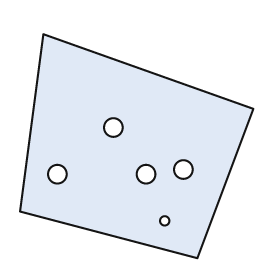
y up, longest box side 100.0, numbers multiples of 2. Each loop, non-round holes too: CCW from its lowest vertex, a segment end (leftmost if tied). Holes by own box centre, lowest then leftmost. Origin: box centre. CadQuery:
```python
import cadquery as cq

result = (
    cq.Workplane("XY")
    .moveTo(26.0, -48.0)
    .lineTo(50.0, 16.0)
    .lineTo(-40.0, 48.0)
    .lineTo(-50.0, -28.0)
    .close()
    .moveTo(12.0, -32.0)
    .circle(2.0)
    .moveTo(-34.0, -12.0)
    .circle(4.0)
    .moveTo(4.0, -12.0)
    .circle(4.0)
    .moveTo(20.0, -10.0)
    .circle(4.0)
    .moveTo(-10.0, 8.0)
    .circle(4.0)
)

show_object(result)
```